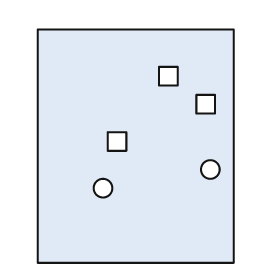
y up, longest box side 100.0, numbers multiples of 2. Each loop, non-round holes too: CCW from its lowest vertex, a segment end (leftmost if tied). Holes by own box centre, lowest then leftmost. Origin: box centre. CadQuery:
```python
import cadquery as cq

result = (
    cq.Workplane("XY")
    .moveTo(-42.0, -50.0)
    .lineTo(42.0, -50.0)
    .lineTo(42.0, 50.0)
    .lineTo(-42.0, 50.0)
    .close()
    .moveTo(-14.0, -18.0)
    .circle(4.0)
    .moveTo(32.0, -10.0)
    .circle(4.0)
    .moveTo(-12.0, -2.0)
    .lineTo(-4.0, -2.0)
    .lineTo(-4.0, 6.0)
    .lineTo(-12.0, 6.0)
    .close()
    .moveTo(26.0, 14.0)
    .lineTo(34.0, 14.0)
    .lineTo(34.0, 22.0)
    .lineTo(26.0, 22.0)
    .close()
    .moveTo(10.0, 26.0)
    .lineTo(18.0, 26.0)
    .lineTo(18.0, 34.0)
    .lineTo(10.0, 34.0)
    .close()
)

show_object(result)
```